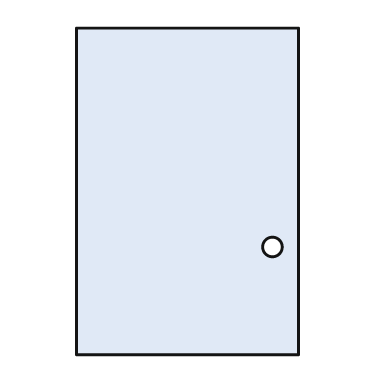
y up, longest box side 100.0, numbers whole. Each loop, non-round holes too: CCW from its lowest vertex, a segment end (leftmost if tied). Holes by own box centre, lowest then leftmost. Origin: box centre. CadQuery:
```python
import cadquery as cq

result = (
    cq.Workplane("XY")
    .moveTo(-34.0, -50.0)
    .lineTo(34.0, -50.0)
    .lineTo(34.0, 50.0)
    .lineTo(-34.0, 50.0)
    .close()
    .moveTo(26.0, -17.0)
    .circle(3.0)
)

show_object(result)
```